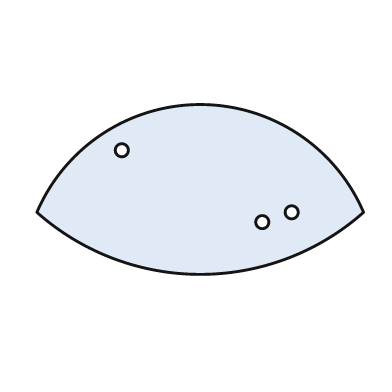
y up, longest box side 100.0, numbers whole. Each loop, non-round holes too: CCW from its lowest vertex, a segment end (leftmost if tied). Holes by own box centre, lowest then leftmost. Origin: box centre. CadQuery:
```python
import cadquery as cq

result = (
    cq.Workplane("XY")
    .moveTo(-50.0, -7.0)
    .threePointArc((0.0, -26.0), (50.0, -7.0))
    .threePointArc((0.0, 26.0), (-50.0, -7.0))
    .close()
    .moveTo(19.0, -10.0)
    .circle(2.0)
    .moveTo(28.0, -7.0)
    .circle(2.0)
    .moveTo(-24.0, 12.0)
    .circle(2.0)
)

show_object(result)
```